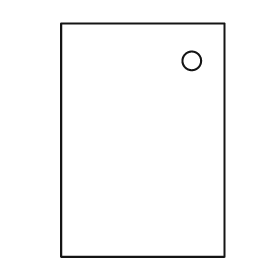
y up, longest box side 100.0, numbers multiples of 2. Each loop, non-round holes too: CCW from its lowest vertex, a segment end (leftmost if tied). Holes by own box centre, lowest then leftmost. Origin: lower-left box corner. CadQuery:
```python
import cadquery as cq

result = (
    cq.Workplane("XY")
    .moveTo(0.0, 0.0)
    .lineTo(70.0, 0.0)
    .lineTo(70.0, 100.0)
    .lineTo(0.0, 100.0)
    .close()
    .moveTo(56.0, 84.0)
    .circle(4.0)
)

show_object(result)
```